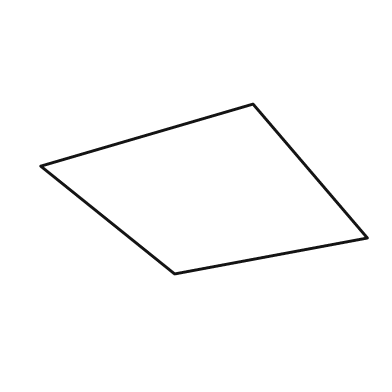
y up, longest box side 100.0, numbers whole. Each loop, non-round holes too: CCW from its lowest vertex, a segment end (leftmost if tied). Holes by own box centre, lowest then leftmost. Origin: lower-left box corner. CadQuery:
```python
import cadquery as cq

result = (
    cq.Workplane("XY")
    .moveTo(41.0, 0.0)
    .lineTo(100.0, 11.0)
    .lineTo(65.0, 52.0)
    .lineTo(0.0, 33.0)
    .close()
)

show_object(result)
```